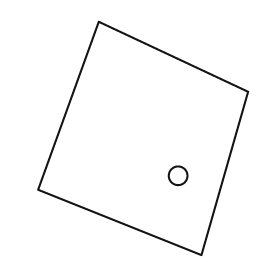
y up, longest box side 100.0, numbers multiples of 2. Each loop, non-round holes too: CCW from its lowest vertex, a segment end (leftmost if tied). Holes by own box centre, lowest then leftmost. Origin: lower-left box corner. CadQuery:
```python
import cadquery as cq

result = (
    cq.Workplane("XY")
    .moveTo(70.0, 0.0)
    .lineTo(90.0, 70.0)
    .lineTo(26.0, 100.0)
    .lineTo(0.0, 28.0)
    .close()
    .moveTo(60.0, 34.0)
    .circle(4.0)
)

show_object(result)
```